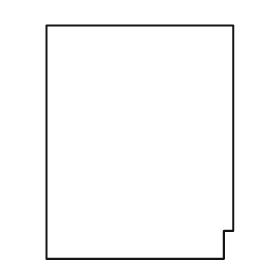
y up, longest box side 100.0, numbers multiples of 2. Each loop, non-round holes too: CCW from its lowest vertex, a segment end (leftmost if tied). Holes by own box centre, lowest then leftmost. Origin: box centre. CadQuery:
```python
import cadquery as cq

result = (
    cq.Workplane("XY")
    .moveTo(-40.0, -50.0)
    .lineTo(36.0, -50.0)
    .lineTo(36.0, -38.0)
    .lineTo(40.0, -38.0)
    .lineTo(40.0, 50.0)
    .lineTo(-40.0, 50.0)
    .close()
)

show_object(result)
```